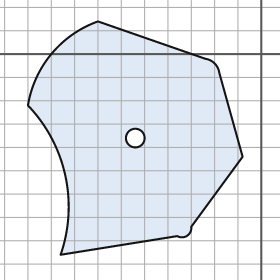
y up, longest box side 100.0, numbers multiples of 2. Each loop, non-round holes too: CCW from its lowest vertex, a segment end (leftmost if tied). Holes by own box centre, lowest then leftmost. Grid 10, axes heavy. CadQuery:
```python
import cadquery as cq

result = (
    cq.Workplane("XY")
    .moveTo(-86.0, -86.0)
    .lineTo(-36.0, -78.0)
    .threePointArc((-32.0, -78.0), (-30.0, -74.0))
    .lineTo(-8.0, -44.0)
    .lineTo(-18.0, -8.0)
    .threePointArc((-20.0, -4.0), (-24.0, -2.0))
    .lineTo(-70.0, 14.0)
    .threePointArc((-90.0, 0.0), (-100.0, -22.0))
    .threePointArc((-84.0, -52.0), (-86.0, -86.0))
    .close()
    .moveTo(-54.0, -36.0)
    .circle(4.0)
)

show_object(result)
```